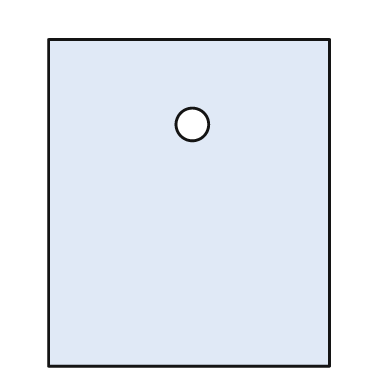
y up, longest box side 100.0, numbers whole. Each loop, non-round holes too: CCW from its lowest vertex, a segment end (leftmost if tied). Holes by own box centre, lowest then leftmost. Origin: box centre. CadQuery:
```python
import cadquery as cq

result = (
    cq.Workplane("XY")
    .moveTo(-43.0, -50.0)
    .lineTo(43.0, -50.0)
    .lineTo(43.0, 50.0)
    .lineTo(-43.0, 50.0)
    .close()
    .moveTo(1.0, 24.0)
    .circle(5.0)
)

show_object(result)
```